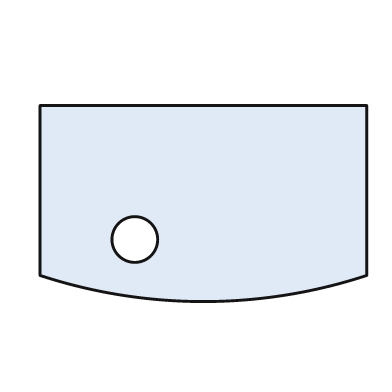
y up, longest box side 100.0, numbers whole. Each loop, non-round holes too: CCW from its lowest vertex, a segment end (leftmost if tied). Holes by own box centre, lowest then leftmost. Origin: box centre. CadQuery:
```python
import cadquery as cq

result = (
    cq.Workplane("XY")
    .moveTo(-50.0, -22.0)
    .threePointArc((0.0, -30.0), (50.0, -22.0))
    .lineTo(50.0, 30.0)
    .lineTo(-50.0, 30.0)
    .close()
    .moveTo(-21.0, -11.0)
    .circle(7.0)
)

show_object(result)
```